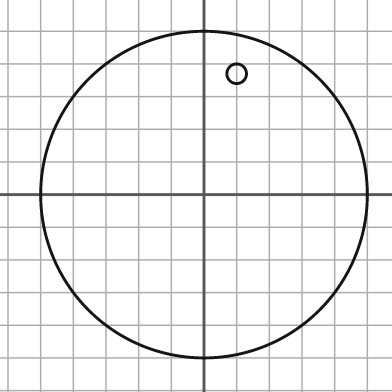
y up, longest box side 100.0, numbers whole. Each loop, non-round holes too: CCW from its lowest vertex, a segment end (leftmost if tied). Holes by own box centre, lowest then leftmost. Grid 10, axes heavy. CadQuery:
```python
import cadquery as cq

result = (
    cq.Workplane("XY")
    .moveTo(0.0, 0.0)
    .circle(50.0)
    .moveTo(10.0, 37.0)
    .circle(3.0)
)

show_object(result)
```